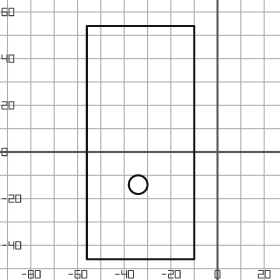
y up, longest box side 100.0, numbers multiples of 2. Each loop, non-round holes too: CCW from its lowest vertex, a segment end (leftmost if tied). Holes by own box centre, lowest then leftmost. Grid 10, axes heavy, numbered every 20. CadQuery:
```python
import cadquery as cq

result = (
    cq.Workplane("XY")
    .moveTo(-56.0, -46.0)
    .lineTo(-10.0, -46.0)
    .lineTo(-10.0, 54.0)
    .lineTo(-56.0, 54.0)
    .close()
    .moveTo(-34.0, -14.0)
    .circle(4.0)
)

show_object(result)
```